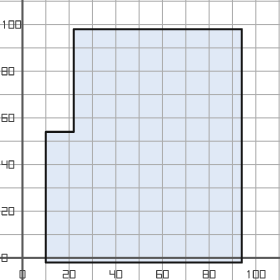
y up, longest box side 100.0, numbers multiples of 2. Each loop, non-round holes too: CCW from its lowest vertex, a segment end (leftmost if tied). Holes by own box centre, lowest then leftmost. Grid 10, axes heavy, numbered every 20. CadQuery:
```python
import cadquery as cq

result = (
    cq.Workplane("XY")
    .moveTo(10.0, -2.0)
    .lineTo(94.0, -2.0)
    .lineTo(94.0, 98.0)
    .lineTo(22.0, 98.0)
    .lineTo(22.0, 54.0)
    .lineTo(10.0, 54.0)
    .close()
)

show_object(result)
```